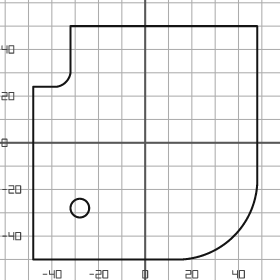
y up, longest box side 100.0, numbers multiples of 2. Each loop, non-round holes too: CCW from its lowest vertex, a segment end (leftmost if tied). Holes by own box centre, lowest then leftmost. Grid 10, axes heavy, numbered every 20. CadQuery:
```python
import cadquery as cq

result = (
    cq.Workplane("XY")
    .moveTo(-48.0, -50.0)
    .lineTo(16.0, -50.0)
    .threePointArc((38.0, -40.0), (48.0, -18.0))
    .lineTo(48.0, 50.0)
    .lineTo(-32.0, 50.0)
    .lineTo(-32.0, 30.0)
    .threePointArc((-34.0, 26.0), (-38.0, 24.0))
    .lineTo(-48.0, 24.0)
    .close()
    .moveTo(-28.0, -28.0)
    .circle(4.0)
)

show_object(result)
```